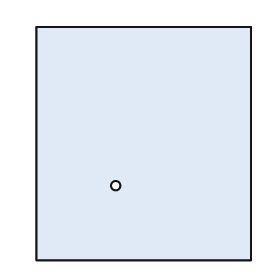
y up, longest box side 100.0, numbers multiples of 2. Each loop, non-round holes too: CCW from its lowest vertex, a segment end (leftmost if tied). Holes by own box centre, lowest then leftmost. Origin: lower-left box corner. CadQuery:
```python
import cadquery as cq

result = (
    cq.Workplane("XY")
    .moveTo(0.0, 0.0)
    .lineTo(92.0, 0.0)
    .lineTo(92.0, 100.0)
    .lineTo(0.0, 100.0)
    .close()
    .moveTo(34.0, 32.0)
    .circle(2.0)
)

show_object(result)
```